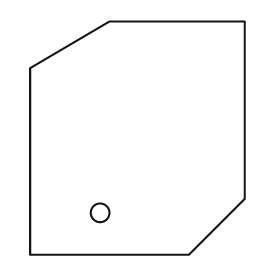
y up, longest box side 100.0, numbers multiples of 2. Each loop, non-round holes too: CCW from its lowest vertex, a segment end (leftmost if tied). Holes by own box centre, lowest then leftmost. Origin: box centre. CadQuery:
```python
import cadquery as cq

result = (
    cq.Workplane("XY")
    .moveTo(-46.0, -50.0)
    .lineTo(22.0, -50.0)
    .lineTo(46.0, -26.0)
    .lineTo(46.0, 50.0)
    .lineTo(-12.0, 50.0)
    .lineTo(-46.0, 30.0)
    .close()
    .moveTo(-16.0, -32.0)
    .circle(4.0)
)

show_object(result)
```